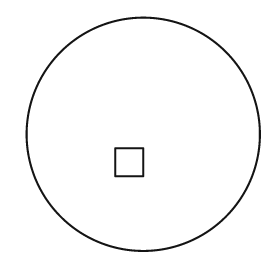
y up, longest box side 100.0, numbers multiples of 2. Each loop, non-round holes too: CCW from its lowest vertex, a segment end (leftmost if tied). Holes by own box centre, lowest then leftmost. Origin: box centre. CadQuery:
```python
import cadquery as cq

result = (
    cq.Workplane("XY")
    .moveTo(0.0, 0.0)
    .circle(50.0)
    .moveTo(-12.0, -18.0)
    .lineTo(0.0, -18.0)
    .lineTo(0.0, -6.0)
    .lineTo(-12.0, -6.0)
    .close()
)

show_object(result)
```